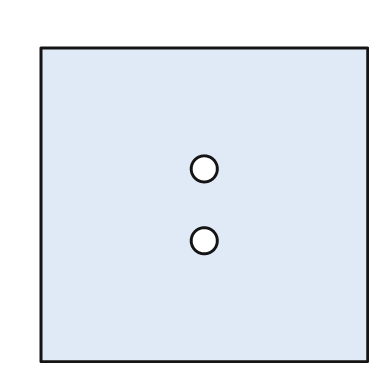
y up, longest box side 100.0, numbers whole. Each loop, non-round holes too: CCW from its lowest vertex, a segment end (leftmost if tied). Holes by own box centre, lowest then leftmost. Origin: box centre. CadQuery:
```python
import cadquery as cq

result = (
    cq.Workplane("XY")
    .moveTo(-50.0, -48.0)
    .lineTo(50.0, -48.0)
    .lineTo(50.0, 48.0)
    .lineTo(-50.0, 48.0)
    .close()
    .moveTo(0.0, -11.0)
    .circle(4.0)
    .moveTo(0.0, 11.0)
    .circle(4.0)
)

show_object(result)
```